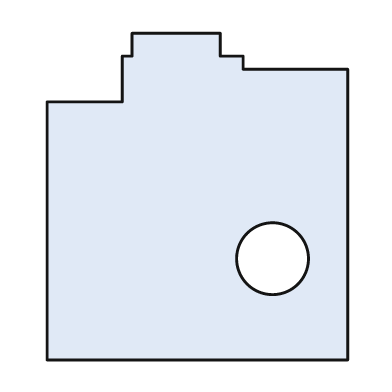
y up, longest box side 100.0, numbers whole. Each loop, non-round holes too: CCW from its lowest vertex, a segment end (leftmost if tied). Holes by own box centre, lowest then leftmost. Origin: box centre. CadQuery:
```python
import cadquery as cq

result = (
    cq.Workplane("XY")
    .moveTo(-46.0, -50.0)
    .lineTo(46.0, -50.0)
    .lineTo(46.0, 39.0)
    .lineTo(14.0, 39.0)
    .lineTo(14.0, 43.0)
    .lineTo(7.0, 43.0)
    .lineTo(7.0, 50.0)
    .lineTo(-20.0, 50.0)
    .lineTo(-20.0, 43.0)
    .lineTo(-23.0, 43.0)
    .lineTo(-23.0, 29.0)
    .lineTo(-46.0, 29.0)
    .close()
    .moveTo(23.0, -19.0)
    .circle(11.0)
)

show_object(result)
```